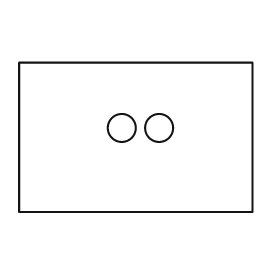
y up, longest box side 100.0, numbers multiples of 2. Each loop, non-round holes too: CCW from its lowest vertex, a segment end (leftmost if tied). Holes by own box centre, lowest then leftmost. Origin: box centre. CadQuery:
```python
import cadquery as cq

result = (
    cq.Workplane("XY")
    .moveTo(-50.0, -32.0)
    .lineTo(50.0, -32.0)
    .lineTo(50.0, 32.0)
    .lineTo(-50.0, 32.0)
    .close()
    .moveTo(-6.0, 4.0)
    .circle(6.0)
    .moveTo(10.0, 4.0)
    .circle(6.0)
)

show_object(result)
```